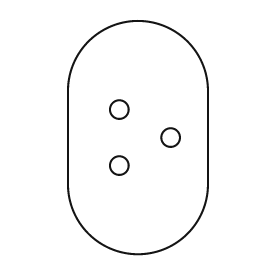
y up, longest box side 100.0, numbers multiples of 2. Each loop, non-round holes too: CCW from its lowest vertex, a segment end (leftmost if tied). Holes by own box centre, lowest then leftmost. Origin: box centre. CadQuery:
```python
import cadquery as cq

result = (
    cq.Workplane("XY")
    .moveTo(-30.0, -20.0)
    .threePointArc((0.0, -50.0), (30.0, -20.0))
    .lineTo(30.0, 20.0)
    .threePointArc((0.0, 50.0), (-30.0, 20.0))
    .close()
    .moveTo(-8.0, -12.0)
    .circle(4.0)
    .moveTo(14.0, 0.0)
    .circle(4.0)
    .moveTo(-8.0, 12.0)
    .circle(4.0)
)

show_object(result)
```